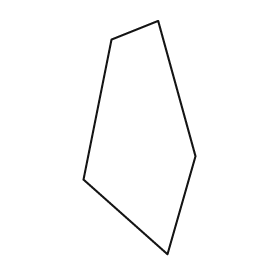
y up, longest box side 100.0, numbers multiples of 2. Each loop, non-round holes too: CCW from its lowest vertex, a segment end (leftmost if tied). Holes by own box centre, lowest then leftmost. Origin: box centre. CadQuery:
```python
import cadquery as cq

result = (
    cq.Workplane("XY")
    .moveTo(12.0, -50.0)
    .lineTo(24.0, -8.0)
    .lineTo(8.0, 50.0)
    .lineTo(-12.0, 42.0)
    .lineTo(-24.0, -18.0)
    .close()
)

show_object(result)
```